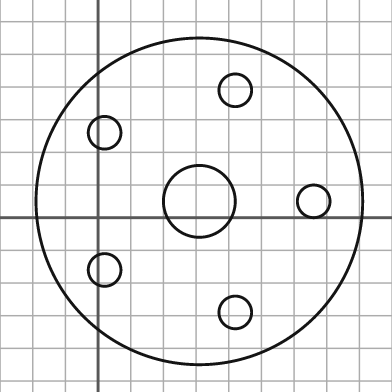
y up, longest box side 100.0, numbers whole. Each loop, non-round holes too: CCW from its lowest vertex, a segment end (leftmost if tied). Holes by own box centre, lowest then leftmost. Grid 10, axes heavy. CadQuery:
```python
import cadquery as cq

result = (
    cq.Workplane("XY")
    .moveTo(31.0, 5.0)
    .circle(50.0)
    .moveTo(42.0, -29.0)
    .circle(5.0)
    .moveTo(2.0, -16.0)
    .circle(5.0)
    .moveTo(31.0, 5.0)
    .circle(11.0)
    .moveTo(66.0, 5.0)
    .circle(5.0)
    .moveTo(2.0, 26.0)
    .circle(5.0)
    .moveTo(42.0, 39.0)
    .circle(5.0)
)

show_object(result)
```